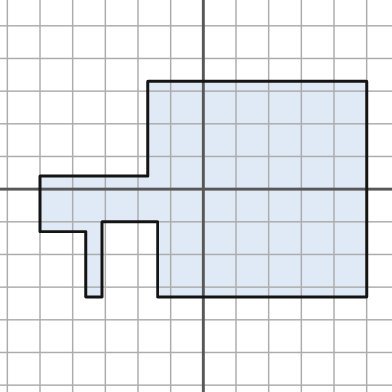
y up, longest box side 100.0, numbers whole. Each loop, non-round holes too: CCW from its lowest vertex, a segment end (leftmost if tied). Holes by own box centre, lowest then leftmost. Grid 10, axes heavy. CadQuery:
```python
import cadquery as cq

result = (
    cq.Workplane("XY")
    .moveTo(-36.0, -33.0)
    .lineTo(-31.0, -33.0)
    .lineTo(-31.0, -10.0)
    .lineTo(-14.0, -10.0)
    .lineTo(-14.0, -33.0)
    .lineTo(50.0, -33.0)
    .lineTo(50.0, 33.0)
    .lineTo(-17.0, 33.0)
    .lineTo(-17.0, 4.0)
    .lineTo(-50.0, 4.0)
    .lineTo(-50.0, -13.0)
    .lineTo(-36.0, -13.0)
    .close()
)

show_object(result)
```